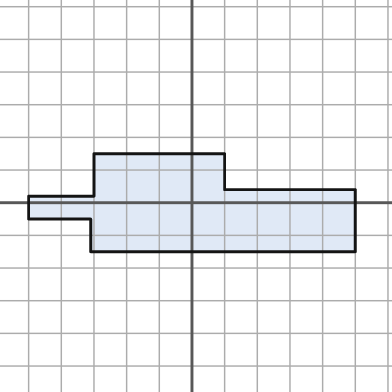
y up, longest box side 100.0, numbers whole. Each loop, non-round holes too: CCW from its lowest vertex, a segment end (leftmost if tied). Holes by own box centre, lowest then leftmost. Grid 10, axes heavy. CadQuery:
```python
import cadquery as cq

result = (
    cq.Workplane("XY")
    .moveTo(-31.0, -15.0)
    .lineTo(50.0, -15.0)
    .lineTo(50.0, 4.0)
    .lineTo(10.0, 4.0)
    .lineTo(10.0, 15.0)
    .lineTo(-30.0, 15.0)
    .lineTo(-30.0, 2.0)
    .lineTo(-50.0, 2.0)
    .lineTo(-50.0, -5.0)
    .lineTo(-31.0, -5.0)
    .close()
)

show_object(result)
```